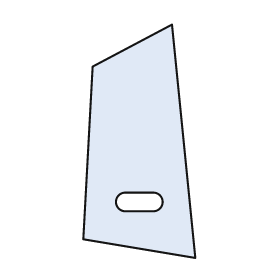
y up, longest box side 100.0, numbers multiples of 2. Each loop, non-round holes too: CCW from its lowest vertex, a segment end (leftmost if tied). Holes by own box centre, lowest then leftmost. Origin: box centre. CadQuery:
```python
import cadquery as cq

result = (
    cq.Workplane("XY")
    .moveTo(24.0, -50.0)
    .lineTo(14.0, 50.0)
    .lineTo(-20.0, 32.0)
    .lineTo(-24.0, -42.0)
    .close()
    .moveTo(-6.0, -30.0)
    .lineTo(6.0, -30.0)
    .threePointArc((10.0, -26.0), (6.0, -22.0))
    .lineTo(-6.0, -22.0)
    .threePointArc((-10.0, -26.0), (-6.0, -30.0))
    .close()
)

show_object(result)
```